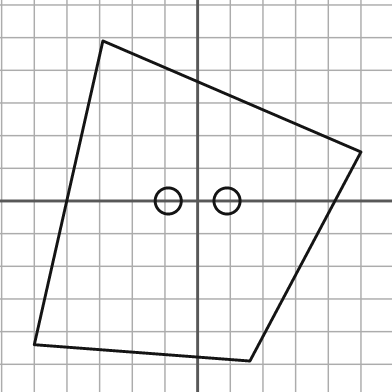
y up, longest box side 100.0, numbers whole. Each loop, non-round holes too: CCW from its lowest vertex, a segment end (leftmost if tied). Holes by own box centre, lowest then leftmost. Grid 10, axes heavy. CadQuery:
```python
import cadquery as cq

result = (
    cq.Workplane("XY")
    .moveTo(16.0, -49.0)
    .lineTo(50.0, 15.0)
    .lineTo(-29.0, 49.0)
    .lineTo(-50.0, -44.0)
    .close()
    .moveTo(-9.0, 0.0)
    .circle(4.0)
    .moveTo(9.0, 0.0)
    .circle(4.0)
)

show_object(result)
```